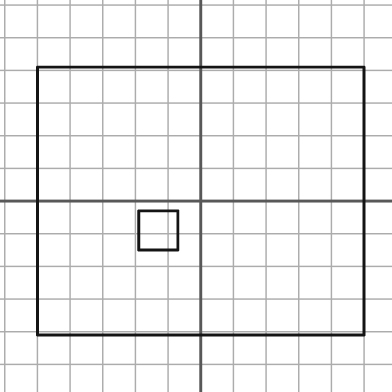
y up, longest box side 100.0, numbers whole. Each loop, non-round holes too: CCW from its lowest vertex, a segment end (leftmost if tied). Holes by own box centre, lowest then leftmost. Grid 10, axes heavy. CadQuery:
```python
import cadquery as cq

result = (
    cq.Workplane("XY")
    .moveTo(-50.0, -41.0)
    .lineTo(50.0, -41.0)
    .lineTo(50.0, 41.0)
    .lineTo(-50.0, 41.0)
    .close()
    .moveTo(-19.0, -15.0)
    .lineTo(-7.0, -15.0)
    .lineTo(-7.0, -3.0)
    .lineTo(-19.0, -3.0)
    .close()
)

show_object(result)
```